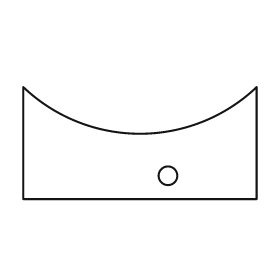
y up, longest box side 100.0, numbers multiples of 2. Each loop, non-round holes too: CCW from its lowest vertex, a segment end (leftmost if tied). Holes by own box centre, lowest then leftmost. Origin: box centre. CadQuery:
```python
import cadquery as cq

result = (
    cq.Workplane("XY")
    .moveTo(-50.0, -24.0)
    .lineTo(50.0, -24.0)
    .lineTo(50.0, 24.0)
    .threePointArc((0.0, 4.0), (-50.0, 24.0))
    .close()
    .moveTo(12.0, -14.0)
    .circle(4.0)
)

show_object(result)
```